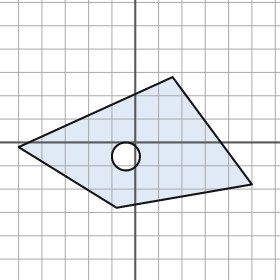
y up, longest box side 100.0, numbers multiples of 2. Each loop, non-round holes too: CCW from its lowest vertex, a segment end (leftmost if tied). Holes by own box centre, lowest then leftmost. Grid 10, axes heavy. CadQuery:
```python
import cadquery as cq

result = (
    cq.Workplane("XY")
    .moveTo(-8.0, -28.0)
    .lineTo(50.0, -18.0)
    .lineTo(16.0, 28.0)
    .lineTo(-50.0, -2.0)
    .close()
    .moveTo(-4.0, -6.0)
    .circle(6.0)
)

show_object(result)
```